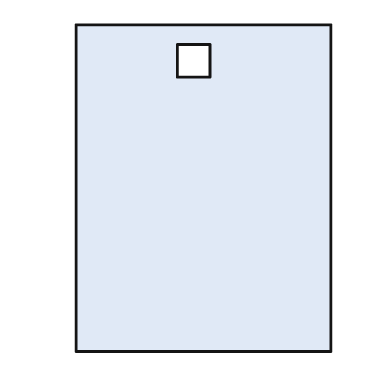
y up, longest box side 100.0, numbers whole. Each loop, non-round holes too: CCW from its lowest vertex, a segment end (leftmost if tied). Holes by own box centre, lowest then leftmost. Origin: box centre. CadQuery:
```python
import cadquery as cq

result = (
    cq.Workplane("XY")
    .moveTo(-39.0, -50.0)
    .lineTo(39.0, -50.0)
    .lineTo(39.0, 50.0)
    .lineTo(-39.0, 50.0)
    .close()
    .moveTo(-8.0, 34.0)
    .lineTo(2.0, 34.0)
    .lineTo(2.0, 44.0)
    .lineTo(-8.0, 44.0)
    .close()
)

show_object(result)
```